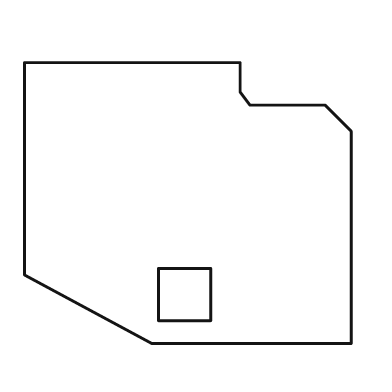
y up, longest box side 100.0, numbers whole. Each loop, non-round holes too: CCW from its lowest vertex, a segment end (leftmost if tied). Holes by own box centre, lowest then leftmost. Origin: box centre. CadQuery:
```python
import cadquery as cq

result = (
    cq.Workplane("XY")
    .moveTo(-11.0, -43.0)
    .lineTo(50.0, -43.0)
    .lineTo(50.0, 22.0)
    .lineTo(42.0, 30.0)
    .lineTo(19.0, 30.0)
    .lineTo(16.0, 34.0)
    .lineTo(16.0, 43.0)
    .lineTo(-50.0, 43.0)
    .lineTo(-50.0, -22.0)
    .close()
    .moveTo(-9.0, -36.0)
    .lineTo(7.0, -36.0)
    .lineTo(7.0, -20.0)
    .lineTo(-9.0, -20.0)
    .close()
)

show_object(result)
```